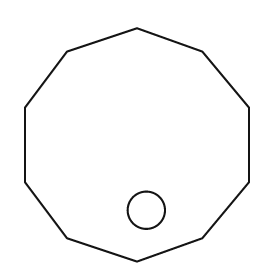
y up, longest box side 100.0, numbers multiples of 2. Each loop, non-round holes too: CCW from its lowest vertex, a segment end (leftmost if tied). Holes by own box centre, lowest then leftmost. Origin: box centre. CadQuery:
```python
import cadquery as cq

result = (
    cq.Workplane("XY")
    .moveTo(0.0, -50.0)
    .lineTo(28.0, -40.0)
    .lineTo(48.0, -16.0)
    .lineTo(48.0, 16.0)
    .lineTo(28.0, 40.0)
    .lineTo(0.0, 50.0)
    .lineTo(-30.0, 40.0)
    .lineTo(-48.0, 16.0)
    .lineTo(-48.0, -16.0)
    .lineTo(-30.0, -40.0)
    .close()
    .moveTo(4.0, -28.0)
    .circle(8.0)
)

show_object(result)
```